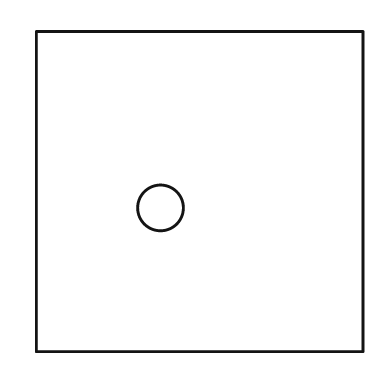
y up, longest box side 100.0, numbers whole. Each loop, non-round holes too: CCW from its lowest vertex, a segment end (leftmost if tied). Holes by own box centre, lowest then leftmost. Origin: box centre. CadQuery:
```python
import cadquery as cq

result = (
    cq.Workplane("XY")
    .moveTo(-50.0, -49.0)
    .lineTo(50.0, -49.0)
    .lineTo(50.0, 49.0)
    .lineTo(-50.0, 49.0)
    .close()
    .moveTo(-12.0, -5.0)
    .circle(7.0)
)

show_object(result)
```